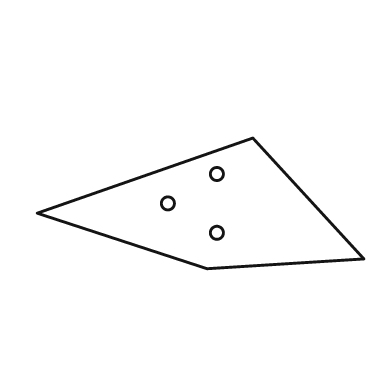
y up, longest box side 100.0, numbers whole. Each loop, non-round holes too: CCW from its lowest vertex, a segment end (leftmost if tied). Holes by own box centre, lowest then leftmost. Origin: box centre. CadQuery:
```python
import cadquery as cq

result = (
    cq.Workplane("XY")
    .moveTo(2.0, -20.0)
    .lineTo(50.0, -17.0)
    .lineTo(16.0, 20.0)
    .lineTo(-50.0, -3.0)
    .close()
    .moveTo(5.0, -9.0)
    .circle(2.0)
    .moveTo(-10.0, 0.0)
    .circle(2.0)
    .moveTo(5.0, 9.0)
    .circle(2.0)
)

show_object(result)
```